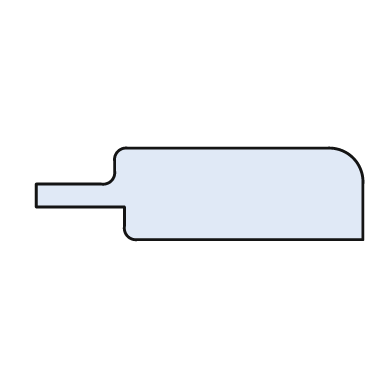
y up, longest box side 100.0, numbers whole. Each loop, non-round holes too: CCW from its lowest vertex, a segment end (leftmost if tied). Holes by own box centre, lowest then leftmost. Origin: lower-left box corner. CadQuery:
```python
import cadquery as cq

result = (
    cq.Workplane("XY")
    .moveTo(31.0, 0.0)
    .lineTo(100.0, 0.0)
    .lineTo(100.0, 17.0)
    .threePointArc((97.0, 25.0), (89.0, 28.0))
    .lineTo(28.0, 28.0)
    .threePointArc((25.0, 27.0), (24.0, 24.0))
    .lineTo(24.0, 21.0)
    .threePointArc((23.0, 18.0), (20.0, 17.0))
    .lineTo(0.0, 17.0)
    .lineTo(0.0, 10.0)
    .lineTo(27.0, 10.0)
    .lineTo(27.0, 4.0)
    .threePointArc((28.0, 1.0), (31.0, 0.0))
    .close()
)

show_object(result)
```